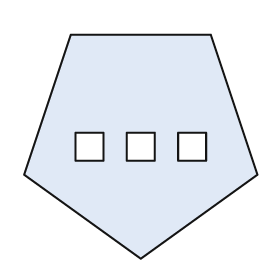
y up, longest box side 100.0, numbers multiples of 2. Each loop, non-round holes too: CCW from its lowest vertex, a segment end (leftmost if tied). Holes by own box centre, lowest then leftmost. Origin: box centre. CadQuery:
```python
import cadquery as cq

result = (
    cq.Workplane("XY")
    .moveTo(0.0, -48.0)
    .lineTo(50.0, -12.0)
    .lineTo(30.0, 48.0)
    .lineTo(-30.0, 48.0)
    .lineTo(-50.0, -12.0)
    .close()
    .moveTo(-28.0, -6.0)
    .lineTo(-16.0, -6.0)
    .lineTo(-16.0, 6.0)
    .lineTo(-28.0, 6.0)
    .close()
    .moveTo(-6.0, -6.0)
    .lineTo(6.0, -6.0)
    .lineTo(6.0, 6.0)
    .lineTo(-6.0, 6.0)
    .close()
    .moveTo(16.0, -6.0)
    .lineTo(28.0, -6.0)
    .lineTo(28.0, 6.0)
    .lineTo(16.0, 6.0)
    .close()
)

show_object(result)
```